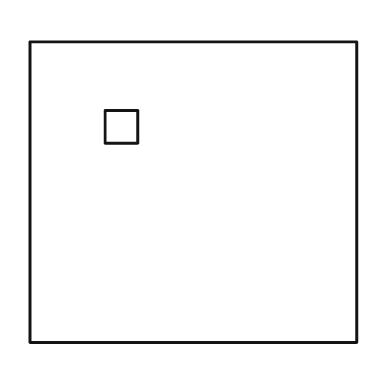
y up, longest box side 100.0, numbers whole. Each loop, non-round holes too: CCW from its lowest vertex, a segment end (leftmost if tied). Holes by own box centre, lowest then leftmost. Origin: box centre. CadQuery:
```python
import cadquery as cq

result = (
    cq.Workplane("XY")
    .moveTo(-50.0, -46.0)
    .lineTo(50.0, -46.0)
    .lineTo(50.0, 46.0)
    .lineTo(-50.0, 46.0)
    .close()
    .moveTo(-27.0, 15.0)
    .lineTo(-17.0, 15.0)
    .lineTo(-17.0, 25.0)
    .lineTo(-27.0, 25.0)
    .close()
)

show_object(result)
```